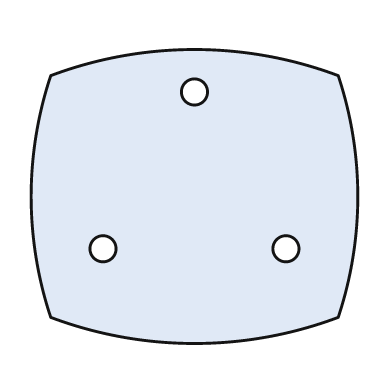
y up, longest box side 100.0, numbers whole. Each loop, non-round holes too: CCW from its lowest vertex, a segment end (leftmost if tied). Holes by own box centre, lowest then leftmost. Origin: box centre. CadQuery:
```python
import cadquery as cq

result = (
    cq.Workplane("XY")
    .moveTo(-44.0, -37.0)
    .threePointArc((0.0, -45.0), (44.0, -37.0))
    .threePointArc((50.0, 0.0), (44.0, 37.0))
    .threePointArc((0.0, 45.0), (-44.0, 37.0))
    .threePointArc((-50.0, 0.0), (-44.0, -37.0))
    .close()
    .moveTo(-28.0, -16.0)
    .circle(4.0)
    .moveTo(28.0, -16.0)
    .circle(4.0)
    .moveTo(0.0, 32.0)
    .circle(4.0)
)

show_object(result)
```